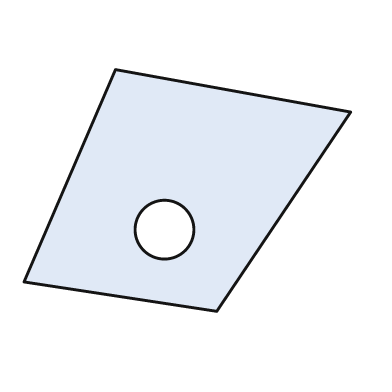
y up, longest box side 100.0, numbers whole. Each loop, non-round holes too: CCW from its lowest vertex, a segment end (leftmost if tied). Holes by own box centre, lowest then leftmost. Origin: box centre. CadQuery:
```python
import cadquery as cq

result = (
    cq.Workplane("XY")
    .moveTo(9.0, -37.0)
    .lineTo(50.0, 24.0)
    .lineTo(-22.0, 37.0)
    .lineTo(-50.0, -28.0)
    .close()
    .moveTo(-7.0, -12.0)
    .circle(9.0)
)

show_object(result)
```